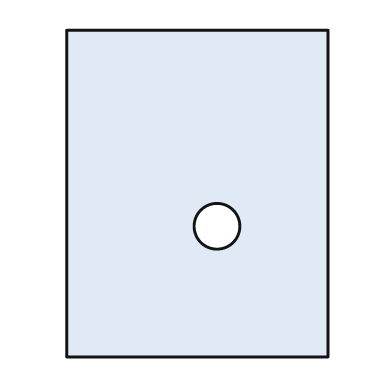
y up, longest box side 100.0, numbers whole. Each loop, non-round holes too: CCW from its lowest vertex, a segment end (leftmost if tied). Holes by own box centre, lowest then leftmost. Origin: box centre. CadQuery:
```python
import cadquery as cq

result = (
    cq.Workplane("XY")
    .moveTo(-40.0, -50.0)
    .lineTo(40.0, -50.0)
    .lineTo(40.0, 50.0)
    .lineTo(-40.0, 50.0)
    .close()
    .moveTo(6.0, -10.0)
    .circle(7.0)
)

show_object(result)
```